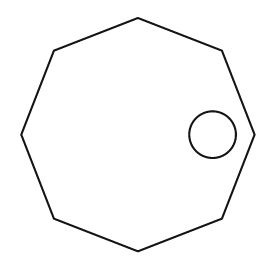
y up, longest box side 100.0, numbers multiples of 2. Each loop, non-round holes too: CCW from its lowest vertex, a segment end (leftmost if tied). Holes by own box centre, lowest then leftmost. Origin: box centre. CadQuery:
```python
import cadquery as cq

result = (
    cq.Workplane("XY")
    .moveTo(0.0, -50.0)
    .lineTo(36.0, -36.0)
    .lineTo(50.0, 0.0)
    .lineTo(36.0, 36.0)
    .lineTo(0.0, 50.0)
    .lineTo(-36.0, 36.0)
    .lineTo(-50.0, 0.0)
    .lineTo(-36.0, -36.0)
    .close()
    .moveTo(32.0, 0.0)
    .circle(10.0)
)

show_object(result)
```